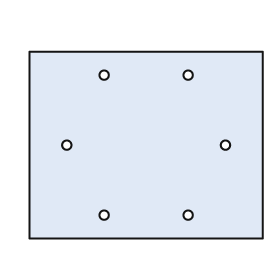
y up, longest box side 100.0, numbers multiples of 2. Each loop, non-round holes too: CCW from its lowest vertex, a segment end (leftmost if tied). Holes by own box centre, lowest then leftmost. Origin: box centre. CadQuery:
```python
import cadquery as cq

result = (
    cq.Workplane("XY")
    .moveTo(-50.0, -40.0)
    .lineTo(50.0, -40.0)
    .lineTo(50.0, 40.0)
    .lineTo(-50.0, 40.0)
    .close()
    .moveTo(-18.0, -30.0)
    .circle(2.0)
    .moveTo(18.0, -30.0)
    .circle(2.0)
    .moveTo(-34.0, 0.0)
    .circle(2.0)
    .moveTo(34.0, 0.0)
    .circle(2.0)
    .moveTo(-18.0, 30.0)
    .circle(2.0)
    .moveTo(18.0, 30.0)
    .circle(2.0)
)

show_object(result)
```